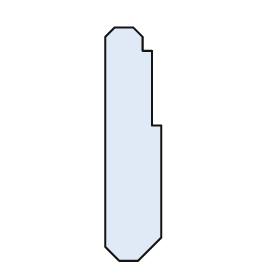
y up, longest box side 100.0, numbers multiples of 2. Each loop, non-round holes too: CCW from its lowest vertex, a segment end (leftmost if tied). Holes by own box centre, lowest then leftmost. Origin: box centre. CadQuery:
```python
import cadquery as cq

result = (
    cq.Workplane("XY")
    .moveTo(-6.0, -50.0)
    .lineTo(2.0, -50.0)
    .lineTo(12.0, -40.0)
    .lineTo(12.0, 8.0)
    .lineTo(8.0, 8.0)
    .lineTo(8.0, 40.0)
    .lineTo(4.0, 40.0)
    .lineTo(4.0, 46.0)
    .lineTo(0.0, 50.0)
    .lineTo(-8.0, 50.0)
    .lineTo(-12.0, 46.0)
    .lineTo(-12.0, -44.0)
    .close()
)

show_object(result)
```